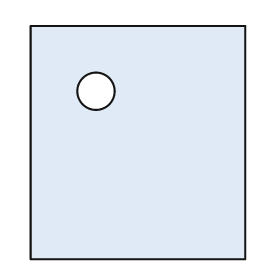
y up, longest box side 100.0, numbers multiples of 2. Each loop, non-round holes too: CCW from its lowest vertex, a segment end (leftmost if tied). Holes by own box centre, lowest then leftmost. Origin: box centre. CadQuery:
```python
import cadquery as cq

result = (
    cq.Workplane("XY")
    .moveTo(-46.0, -50.0)
    .lineTo(46.0, -50.0)
    .lineTo(46.0, 50.0)
    .lineTo(-46.0, 50.0)
    .close()
    .moveTo(-18.0, 22.0)
    .circle(8.0)
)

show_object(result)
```